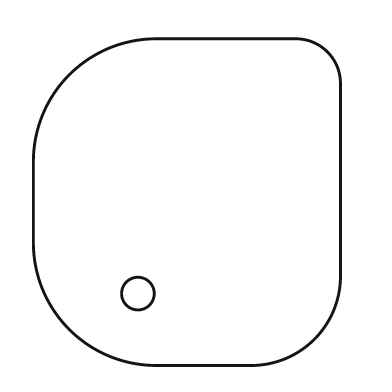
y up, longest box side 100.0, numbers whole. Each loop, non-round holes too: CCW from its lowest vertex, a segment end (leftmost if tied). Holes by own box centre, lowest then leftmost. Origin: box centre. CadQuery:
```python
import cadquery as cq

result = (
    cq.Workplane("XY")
    .moveTo(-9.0, -50.0)
    .lineTo(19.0, -50.0)
    .threePointArc((39.0, -42.0), (47.0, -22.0))
    .lineTo(47.0, 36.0)
    .threePointArc((43.0, 46.0), (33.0, 50.0))
    .lineTo(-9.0, 50.0)
    .threePointArc((-36.0, 39.0), (-47.0, 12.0))
    .lineTo(-47.0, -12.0)
    .threePointArc((-36.0, -39.0), (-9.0, -50.0))
    .close()
    .moveTo(-15.0, -28.0)
    .circle(5.0)
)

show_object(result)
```